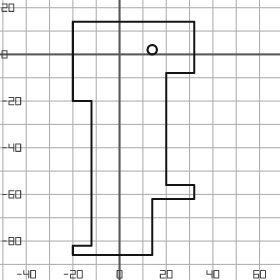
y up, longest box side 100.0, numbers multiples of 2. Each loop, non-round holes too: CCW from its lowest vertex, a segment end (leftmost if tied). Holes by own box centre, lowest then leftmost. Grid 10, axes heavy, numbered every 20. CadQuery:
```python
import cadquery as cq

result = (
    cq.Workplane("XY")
    .moveTo(-20.0, -86.0)
    .lineTo(14.0, -86.0)
    .lineTo(14.0, -62.0)
    .lineTo(32.0, -62.0)
    .lineTo(32.0, -56.0)
    .lineTo(20.0, -56.0)
    .lineTo(20.0, -8.0)
    .lineTo(32.0, -8.0)
    .lineTo(32.0, 14.0)
    .lineTo(-20.0, 14.0)
    .lineTo(-20.0, -20.0)
    .lineTo(-12.0, -20.0)
    .lineTo(-12.0, -82.0)
    .lineTo(-20.0, -82.0)
    .close()
    .moveTo(14.0, 2.0)
    .circle(2.0)
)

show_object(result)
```